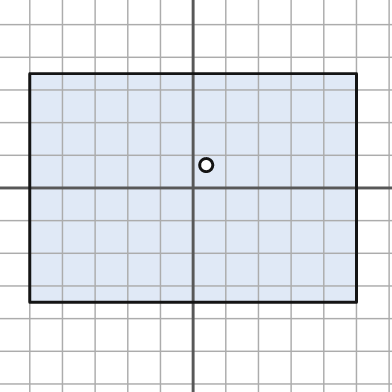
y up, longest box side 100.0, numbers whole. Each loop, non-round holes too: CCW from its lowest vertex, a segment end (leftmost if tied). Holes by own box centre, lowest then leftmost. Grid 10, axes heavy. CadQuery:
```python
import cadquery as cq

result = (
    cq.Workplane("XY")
    .moveTo(-50.0, -35.0)
    .lineTo(50.0, -35.0)
    .lineTo(50.0, 35.0)
    .lineTo(-50.0, 35.0)
    .close()
    .moveTo(4.0, 7.0)
    .circle(2.0)
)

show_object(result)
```